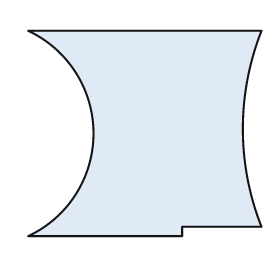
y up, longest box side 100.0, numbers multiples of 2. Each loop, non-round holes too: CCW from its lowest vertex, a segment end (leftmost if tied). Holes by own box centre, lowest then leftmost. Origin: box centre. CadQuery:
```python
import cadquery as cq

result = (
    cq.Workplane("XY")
    .moveTo(-50.0, -44.0)
    .lineTo(16.0, -44.0)
    .lineTo(16.0, -40.0)
    .lineTo(50.0, -40.0)
    .threePointArc((42.0, 2.0), (50.0, 44.0))
    .lineTo(-50.0, 44.0)
    .threePointArc((-22.0, 0.0), (-50.0, -44.0))
    .close()
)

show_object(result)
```